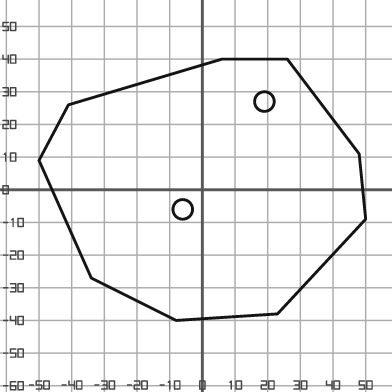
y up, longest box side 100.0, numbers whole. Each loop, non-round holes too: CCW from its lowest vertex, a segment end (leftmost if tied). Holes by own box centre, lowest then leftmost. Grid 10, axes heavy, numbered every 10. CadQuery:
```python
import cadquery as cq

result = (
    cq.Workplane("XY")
    .moveTo(-8.0, -40.0)
    .lineTo(23.0, -38.0)
    .lineTo(50.0, -9.0)
    .lineTo(48.0, 11.0)
    .lineTo(26.0, 40.0)
    .lineTo(6.0, 40.0)
    .lineTo(-41.0, 26.0)
    .lineTo(-50.0, 9.0)
    .lineTo(-34.0, -27.0)
    .close()
    .moveTo(-6.0, -6.0)
    .circle(3.0)
    .moveTo(19.0, 27.0)
    .circle(3.0)
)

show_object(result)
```